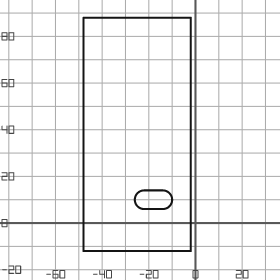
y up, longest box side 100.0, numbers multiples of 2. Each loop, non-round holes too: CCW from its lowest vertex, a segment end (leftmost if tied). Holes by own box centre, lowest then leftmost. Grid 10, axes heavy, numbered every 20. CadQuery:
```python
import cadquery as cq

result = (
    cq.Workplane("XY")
    .moveTo(-48.0, -12.0)
    .lineTo(-2.0, -12.0)
    .lineTo(-2.0, 88.0)
    .lineTo(-48.0, 88.0)
    .close()
    .moveTo(-22.0, 6.0)
    .lineTo(-14.0, 6.0)
    .threePointArc((-10.0, 10.0), (-14.0, 14.0))
    .lineTo(-22.0, 14.0)
    .threePointArc((-26.0, 10.0), (-22.0, 6.0))
    .close()
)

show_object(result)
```